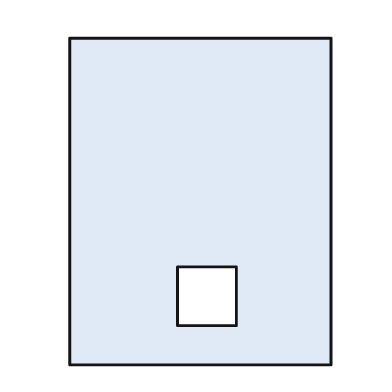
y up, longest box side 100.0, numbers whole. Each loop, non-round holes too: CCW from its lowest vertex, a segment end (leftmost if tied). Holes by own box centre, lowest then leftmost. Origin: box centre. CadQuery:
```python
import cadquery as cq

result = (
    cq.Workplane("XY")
    .moveTo(-40.0, -50.0)
    .lineTo(40.0, -50.0)
    .lineTo(40.0, 50.0)
    .lineTo(-40.0, 50.0)
    .close()
    .moveTo(-7.0, -38.0)
    .lineTo(11.0, -38.0)
    .lineTo(11.0, -20.0)
    .lineTo(-7.0, -20.0)
    .close()
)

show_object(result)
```